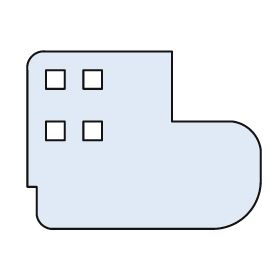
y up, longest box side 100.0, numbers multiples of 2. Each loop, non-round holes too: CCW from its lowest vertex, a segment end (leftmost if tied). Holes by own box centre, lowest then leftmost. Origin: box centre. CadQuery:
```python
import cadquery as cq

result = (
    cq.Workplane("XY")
    .moveTo(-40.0, -38.0)
    .lineTo(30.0, -38.0)
    .threePointArc((44.0, -32.0), (50.0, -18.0))
    .lineTo(50.0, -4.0)
    .threePointArc((46.0, 4.0), (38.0, 8.0))
    .lineTo(12.0, 8.0)
    .lineTo(12.0, 38.0)
    .lineTo(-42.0, 38.0)
    .threePointArc((-48.0, 36.0), (-50.0, 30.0))
    .lineTo(-50.0, -20.0)
    .lineTo(-46.0, -20.0)
    .lineTo(-46.0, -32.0)
    .threePointArc((-44.0, -36.0), (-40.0, -38.0))
    .close()
    .moveTo(-42.0, 0.0)
    .lineTo(-34.0, 0.0)
    .lineTo(-34.0, 8.0)
    .lineTo(-42.0, 8.0)
    .close()
    .moveTo(-26.0, 0.0)
    .lineTo(-18.0, 0.0)
    .lineTo(-18.0, 8.0)
    .lineTo(-26.0, 8.0)
    .close()
    .moveTo(-42.0, 22.0)
    .lineTo(-34.0, 22.0)
    .lineTo(-34.0, 30.0)
    .lineTo(-42.0, 30.0)
    .close()
    .moveTo(-26.0, 22.0)
    .lineTo(-18.0, 22.0)
    .lineTo(-18.0, 30.0)
    .lineTo(-26.0, 30.0)
    .close()
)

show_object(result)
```